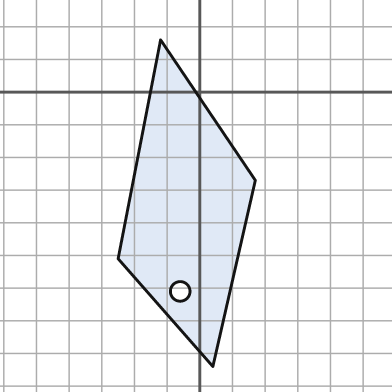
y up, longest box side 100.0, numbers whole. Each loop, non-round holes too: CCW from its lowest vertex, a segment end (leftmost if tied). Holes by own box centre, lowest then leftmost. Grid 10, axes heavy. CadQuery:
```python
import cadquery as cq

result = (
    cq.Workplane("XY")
    .moveTo(4.0, -84.0)
    .lineTo(17.0, -27.0)
    .lineTo(-12.0, 16.0)
    .lineTo(-25.0, -51.0)
    .close()
    .moveTo(-6.0, -61.0)
    .circle(3.0)
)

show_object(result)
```